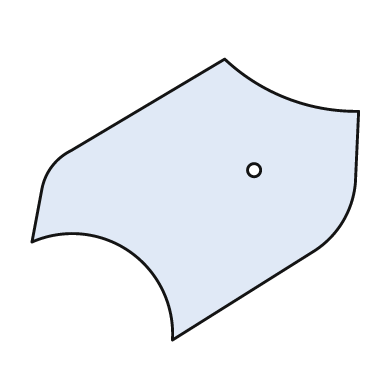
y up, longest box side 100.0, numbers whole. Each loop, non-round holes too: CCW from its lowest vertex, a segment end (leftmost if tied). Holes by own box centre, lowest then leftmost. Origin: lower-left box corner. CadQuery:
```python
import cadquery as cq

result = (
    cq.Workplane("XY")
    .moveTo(43.0, 0.0)
    .lineTo(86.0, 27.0)
    .threePointArc((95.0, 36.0), (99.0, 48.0))
    .lineTo(100.0, 70.0)
    .threePointArc((78.0, 74.0), (59.0, 86.0))
    .lineTo(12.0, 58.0)
    .threePointArc((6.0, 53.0), (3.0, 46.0))
    .lineTo(0.0, 30.0)
    .threePointArc((30.0, 27.0), (43.0, 0.0))
    .close()
    .moveTo(68.0, 52.0)
    .circle(2.0)
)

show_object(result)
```